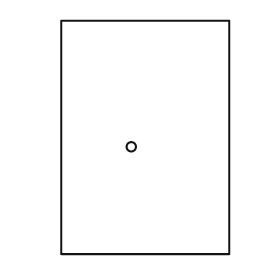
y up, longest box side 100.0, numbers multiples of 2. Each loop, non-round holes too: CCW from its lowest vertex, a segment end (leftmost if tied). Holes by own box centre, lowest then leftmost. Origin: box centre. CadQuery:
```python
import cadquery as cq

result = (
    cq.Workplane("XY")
    .moveTo(-36.0, -50.0)
    .lineTo(36.0, -50.0)
    .lineTo(36.0, 50.0)
    .lineTo(-36.0, 50.0)
    .close()
    .moveTo(-6.0, -4.0)
    .circle(2.0)
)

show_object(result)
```